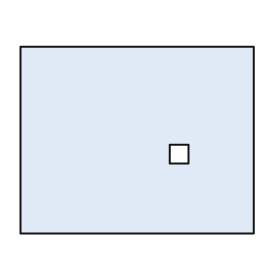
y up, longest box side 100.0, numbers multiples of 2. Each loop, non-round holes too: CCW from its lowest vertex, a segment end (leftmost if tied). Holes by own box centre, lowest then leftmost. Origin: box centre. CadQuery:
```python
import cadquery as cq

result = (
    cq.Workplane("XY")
    .moveTo(-50.0, -40.0)
    .lineTo(50.0, -40.0)
    .lineTo(50.0, 40.0)
    .lineTo(-50.0, 40.0)
    .close()
    .moveTo(14.0, -10.0)
    .lineTo(22.0, -10.0)
    .lineTo(22.0, -2.0)
    .lineTo(14.0, -2.0)
    .close()
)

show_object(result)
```